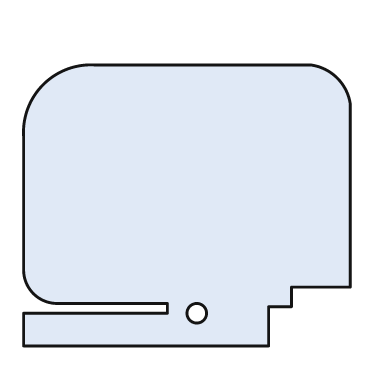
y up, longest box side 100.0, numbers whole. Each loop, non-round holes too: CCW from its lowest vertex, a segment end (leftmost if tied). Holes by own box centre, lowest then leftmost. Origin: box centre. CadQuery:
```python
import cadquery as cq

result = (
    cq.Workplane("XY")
    .moveTo(-50.0, -43.0)
    .lineTo(25.0, -43.0)
    .lineTo(25.0, -31.0)
    .lineTo(32.0, -31.0)
    .lineTo(32.0, -25.0)
    .lineTo(50.0, -25.0)
    .lineTo(50.0, 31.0)
    .threePointArc((46.0, 39.0), (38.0, 43.0))
    .lineTo(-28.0, 43.0)
    .threePointArc((-44.0, 37.0), (-50.0, 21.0))
    .lineTo(-50.0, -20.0)
    .threePointArc((-47.0, -27.0), (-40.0, -30.0))
    .lineTo(-6.0, -30.0)
    .lineTo(-6.0, -33.0)
    .lineTo(-50.0, -33.0)
    .close()
    .moveTo(3.0, -33.0)
    .circle(3.0)
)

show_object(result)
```